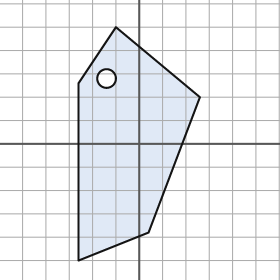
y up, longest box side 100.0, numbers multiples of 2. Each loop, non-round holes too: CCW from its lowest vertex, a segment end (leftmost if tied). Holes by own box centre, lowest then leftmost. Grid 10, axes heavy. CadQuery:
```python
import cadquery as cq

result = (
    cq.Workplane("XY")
    .moveTo(-26.0, -50.0)
    .lineTo(4.0, -38.0)
    .lineTo(26.0, 20.0)
    .lineTo(-10.0, 50.0)
    .lineTo(-26.0, 26.0)
    .close()
    .moveTo(-14.0, 28.0)
    .circle(4.0)
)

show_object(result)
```